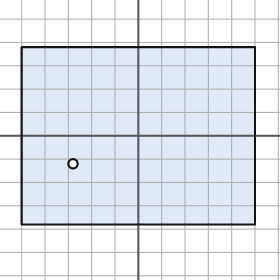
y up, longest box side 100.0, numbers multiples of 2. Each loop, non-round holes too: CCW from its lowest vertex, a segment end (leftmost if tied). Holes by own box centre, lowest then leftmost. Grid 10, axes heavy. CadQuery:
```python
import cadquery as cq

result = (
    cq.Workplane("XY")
    .moveTo(-50.0, -38.0)
    .lineTo(50.0, -38.0)
    .lineTo(50.0, 38.0)
    .lineTo(-50.0, 38.0)
    .close()
    .moveTo(-28.0, -12.0)
    .circle(2.0)
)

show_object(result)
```